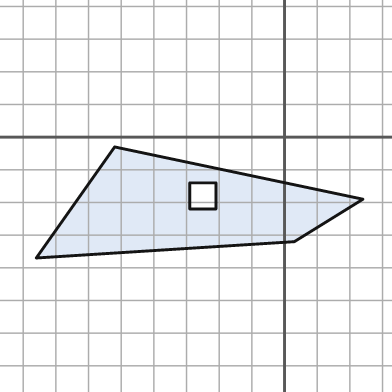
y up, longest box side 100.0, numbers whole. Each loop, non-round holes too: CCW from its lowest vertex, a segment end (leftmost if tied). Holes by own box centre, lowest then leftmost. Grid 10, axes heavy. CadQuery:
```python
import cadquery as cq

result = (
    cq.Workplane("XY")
    .moveTo(-76.0, -37.0)
    .lineTo(3.0, -32.0)
    .lineTo(24.0, -19.0)
    .lineTo(-52.0, -3.0)
    .close()
    .moveTo(-29.0, -22.0)
    .lineTo(-21.0, -22.0)
    .lineTo(-21.0, -14.0)
    .lineTo(-29.0, -14.0)
    .close()
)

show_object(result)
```